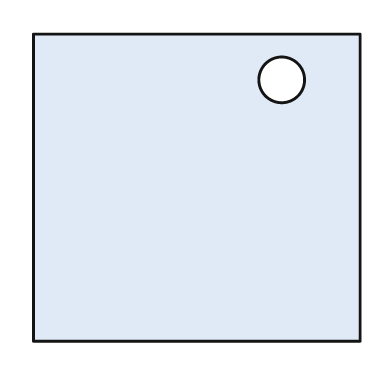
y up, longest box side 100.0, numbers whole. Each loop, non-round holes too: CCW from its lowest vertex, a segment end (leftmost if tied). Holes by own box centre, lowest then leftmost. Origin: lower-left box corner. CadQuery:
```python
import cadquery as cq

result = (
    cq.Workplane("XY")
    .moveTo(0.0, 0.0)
    .lineTo(100.0, 0.0)
    .lineTo(100.0, 94.0)
    .lineTo(0.0, 94.0)
    .close()
    .moveTo(76.0, 80.0)
    .circle(7.0)
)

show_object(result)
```